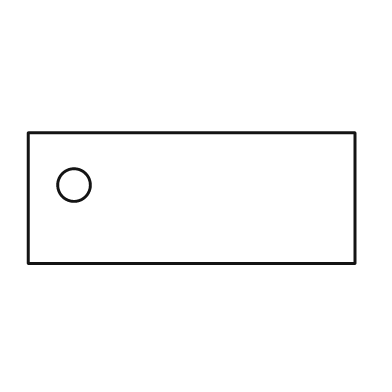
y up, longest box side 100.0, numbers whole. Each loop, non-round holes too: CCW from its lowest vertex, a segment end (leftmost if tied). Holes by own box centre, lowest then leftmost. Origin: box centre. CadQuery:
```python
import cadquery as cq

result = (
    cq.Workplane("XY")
    .moveTo(-50.0, -20.0)
    .lineTo(50.0, -20.0)
    .lineTo(50.0, 20.0)
    .lineTo(-50.0, 20.0)
    .close()
    .moveTo(-36.0, 4.0)
    .circle(5.0)
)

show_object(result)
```